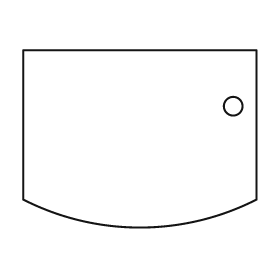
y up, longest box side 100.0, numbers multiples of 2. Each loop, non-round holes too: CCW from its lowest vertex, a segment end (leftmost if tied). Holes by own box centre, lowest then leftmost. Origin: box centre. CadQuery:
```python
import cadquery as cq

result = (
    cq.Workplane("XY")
    .moveTo(-50.0, -26.0)
    .threePointArc((0.0, -38.0), (50.0, -26.0))
    .lineTo(50.0, 38.0)
    .lineTo(-50.0, 38.0)
    .close()
    .moveTo(40.0, 14.0)
    .circle(4.0)
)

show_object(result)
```